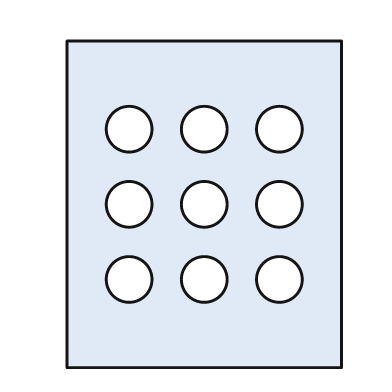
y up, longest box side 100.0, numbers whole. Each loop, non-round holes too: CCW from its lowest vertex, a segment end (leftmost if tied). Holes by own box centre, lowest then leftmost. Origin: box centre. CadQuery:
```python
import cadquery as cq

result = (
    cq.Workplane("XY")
    .moveTo(-42.0, -50.0)
    .lineTo(42.0, -50.0)
    .lineTo(42.0, 50.0)
    .lineTo(-42.0, 50.0)
    .close()
    .moveTo(-23.0, -23.0)
    .circle(7.0)
    .moveTo(0.0, -23.0)
    .circle(7.0)
    .moveTo(23.0, -23.0)
    .circle(7.0)
    .moveTo(-23.0, 0.0)
    .circle(7.0)
    .moveTo(0.0, 0.0)
    .circle(7.0)
    .moveTo(23.0, 0.0)
    .circle(7.0)
    .moveTo(-23.0, 23.0)
    .circle(7.0)
    .moveTo(0.0, 23.0)
    .circle(7.0)
    .moveTo(23.0, 23.0)
    .circle(7.0)
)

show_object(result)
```